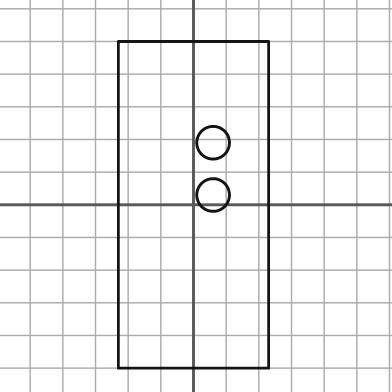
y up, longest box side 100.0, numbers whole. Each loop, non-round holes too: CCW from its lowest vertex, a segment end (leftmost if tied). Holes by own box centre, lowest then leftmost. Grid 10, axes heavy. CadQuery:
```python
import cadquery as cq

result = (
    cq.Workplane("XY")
    .moveTo(-23.0, -50.0)
    .lineTo(23.0, -50.0)
    .lineTo(23.0, 50.0)
    .lineTo(-23.0, 50.0)
    .close()
    .moveTo(6.0, 3.0)
    .circle(5.0)
    .moveTo(6.0, 19.0)
    .circle(5.0)
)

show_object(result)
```